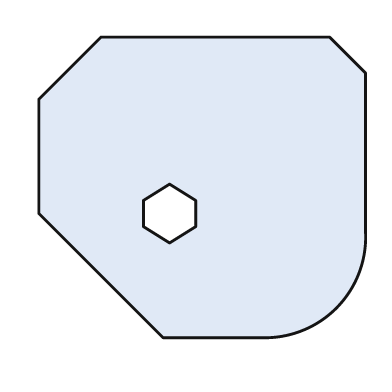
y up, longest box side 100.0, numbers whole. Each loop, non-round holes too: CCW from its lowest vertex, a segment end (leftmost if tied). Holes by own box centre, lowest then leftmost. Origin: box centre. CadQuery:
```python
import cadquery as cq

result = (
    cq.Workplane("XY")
    .moveTo(-12.0, -46.0)
    .lineTo(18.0, -46.0)
    .threePointArc((41.0, -37.0), (50.0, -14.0))
    .lineTo(50.0, 35.0)
    .lineTo(39.0, 46.0)
    .lineTo(-31.0, 46.0)
    .lineTo(-50.0, 27.0)
    .lineTo(-50.0, -8.0)
    .close()
    .moveTo(-10.0, -17.0)
    .lineTo(-2.0, -12.0)
    .lineTo(-2.0, -4.0)
    .lineTo(-10.0, 1.0)
    .lineTo(-18.0, -4.0)
    .lineTo(-18.0, -12.0)
    .close()
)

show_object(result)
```